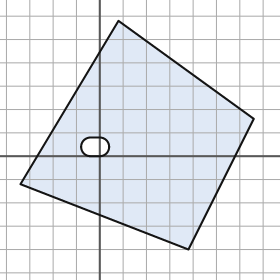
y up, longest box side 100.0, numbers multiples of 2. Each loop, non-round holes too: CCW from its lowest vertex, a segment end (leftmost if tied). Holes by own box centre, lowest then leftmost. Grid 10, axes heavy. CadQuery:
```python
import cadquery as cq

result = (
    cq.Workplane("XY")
    .moveTo(38.0, -40.0)
    .lineTo(66.0, 16.0)
    .lineTo(8.0, 58.0)
    .lineTo(-34.0, -12.0)
    .close()
    .moveTo(-4.0, 0.0)
    .lineTo(0.0, 0.0)
    .threePointArc((4.0, 4.0), (0.0, 8.0))
    .lineTo(-4.0, 8.0)
    .threePointArc((-8.0, 4.0), (-4.0, 0.0))
    .close()
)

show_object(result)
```